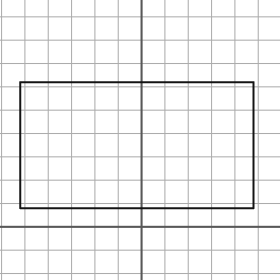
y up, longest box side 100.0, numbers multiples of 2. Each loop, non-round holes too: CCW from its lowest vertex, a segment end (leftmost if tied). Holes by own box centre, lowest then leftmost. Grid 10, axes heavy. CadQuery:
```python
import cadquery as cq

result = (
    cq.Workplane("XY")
    .moveTo(-52.0, 8.0)
    .lineTo(48.0, 8.0)
    .lineTo(48.0, 62.0)
    .lineTo(-52.0, 62.0)
    .close()
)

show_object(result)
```